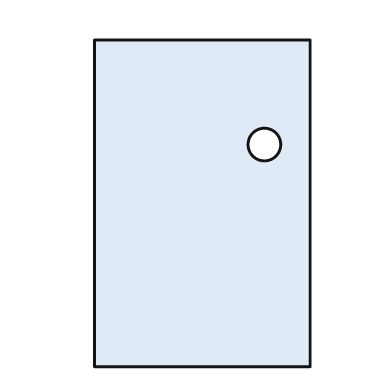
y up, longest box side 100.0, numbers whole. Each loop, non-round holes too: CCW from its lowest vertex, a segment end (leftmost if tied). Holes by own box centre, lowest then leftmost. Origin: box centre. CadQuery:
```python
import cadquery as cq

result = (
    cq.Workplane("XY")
    .moveTo(-33.0, -50.0)
    .lineTo(33.0, -50.0)
    .lineTo(33.0, 50.0)
    .lineTo(-33.0, 50.0)
    .close()
    .moveTo(19.0, 18.0)
    .circle(5.0)
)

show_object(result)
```